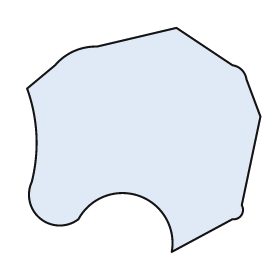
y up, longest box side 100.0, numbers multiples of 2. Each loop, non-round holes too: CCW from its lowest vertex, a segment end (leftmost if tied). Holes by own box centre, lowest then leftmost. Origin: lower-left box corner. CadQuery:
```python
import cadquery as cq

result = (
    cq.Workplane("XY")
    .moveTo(62.0, 0.0)
    .lineTo(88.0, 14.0)
    .threePointArc((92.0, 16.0), (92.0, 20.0))
    .lineTo(100.0, 58.0)
    .lineTo(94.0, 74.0)
    .threePointArc((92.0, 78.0), (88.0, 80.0))
    .lineTo(64.0, 96.0)
    .lineTo(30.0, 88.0)
    .threePointArc((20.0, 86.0), (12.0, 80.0))
    .lineTo(0.0, 70.0)
    .threePointArc((4.0, 50.0), (2.0, 30.0))
    .threePointArc((6.0, 14.0), (22.0, 14.0))
    .threePointArc((48.0, 24.0), (62.0, 0.0))
    .close()
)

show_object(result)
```